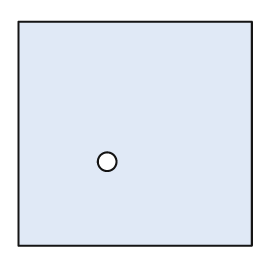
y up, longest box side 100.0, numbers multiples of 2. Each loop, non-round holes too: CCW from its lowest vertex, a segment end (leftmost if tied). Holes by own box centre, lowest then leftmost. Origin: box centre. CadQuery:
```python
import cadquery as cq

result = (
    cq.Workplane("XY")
    .moveTo(-50.0, -48.0)
    .lineTo(50.0, -48.0)
    .lineTo(50.0, 48.0)
    .lineTo(-50.0, 48.0)
    .close()
    .moveTo(-12.0, -12.0)
    .circle(4.0)
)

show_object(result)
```